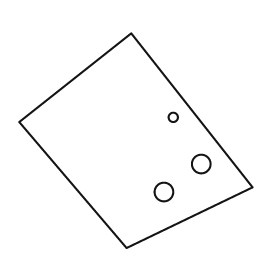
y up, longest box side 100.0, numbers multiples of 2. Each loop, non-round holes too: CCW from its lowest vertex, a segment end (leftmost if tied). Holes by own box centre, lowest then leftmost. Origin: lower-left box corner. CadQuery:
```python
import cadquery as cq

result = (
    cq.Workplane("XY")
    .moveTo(46.0, 0.0)
    .lineTo(100.0, 26.0)
    .lineTo(48.0, 92.0)
    .lineTo(0.0, 54.0)
    .close()
    .moveTo(62.0, 24.0)
    .circle(4.0)
    .moveTo(78.0, 36.0)
    .circle(4.0)
    .moveTo(66.0, 56.0)
    .circle(2.0)
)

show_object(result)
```